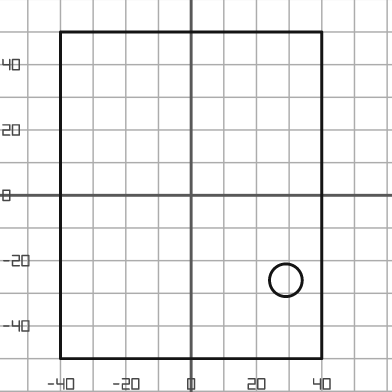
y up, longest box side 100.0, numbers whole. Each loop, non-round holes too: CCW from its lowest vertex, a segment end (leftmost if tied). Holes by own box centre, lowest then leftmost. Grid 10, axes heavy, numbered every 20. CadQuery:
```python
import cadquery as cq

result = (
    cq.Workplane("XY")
    .moveTo(-40.0, -50.0)
    .lineTo(40.0, -50.0)
    .lineTo(40.0, 50.0)
    .lineTo(-40.0, 50.0)
    .close()
    .moveTo(29.0, -26.0)
    .circle(5.0)
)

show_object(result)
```